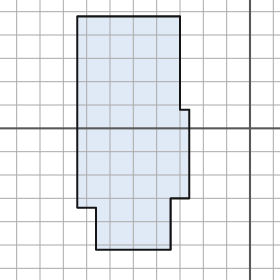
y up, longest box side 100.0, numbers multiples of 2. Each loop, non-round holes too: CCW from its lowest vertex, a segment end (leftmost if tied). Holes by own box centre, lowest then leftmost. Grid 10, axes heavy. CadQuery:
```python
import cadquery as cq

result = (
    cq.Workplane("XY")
    .moveTo(-66.0, -52.0)
    .lineTo(-34.0, -52.0)
    .lineTo(-34.0, -30.0)
    .lineTo(-26.0, -30.0)
    .lineTo(-26.0, 8.0)
    .lineTo(-30.0, 8.0)
    .lineTo(-30.0, 48.0)
    .lineTo(-74.0, 48.0)
    .lineTo(-74.0, -34.0)
    .lineTo(-66.0, -34.0)
    .close()
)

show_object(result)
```